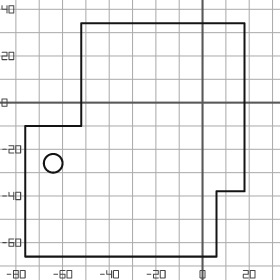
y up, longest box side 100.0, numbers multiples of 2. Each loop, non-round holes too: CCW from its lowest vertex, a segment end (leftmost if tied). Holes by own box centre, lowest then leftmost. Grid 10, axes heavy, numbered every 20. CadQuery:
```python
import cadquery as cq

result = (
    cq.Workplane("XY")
    .moveTo(-76.0, -66.0)
    .lineTo(6.0, -66.0)
    .lineTo(6.0, -38.0)
    .lineTo(18.0, -38.0)
    .lineTo(18.0, 34.0)
    .lineTo(-52.0, 34.0)
    .lineTo(-52.0, -10.0)
    .lineTo(-76.0, -10.0)
    .close()
    .moveTo(-64.0, -26.0)
    .circle(4.0)
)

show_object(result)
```